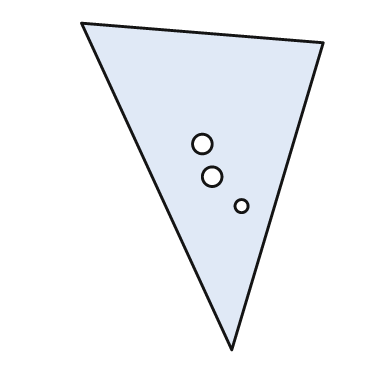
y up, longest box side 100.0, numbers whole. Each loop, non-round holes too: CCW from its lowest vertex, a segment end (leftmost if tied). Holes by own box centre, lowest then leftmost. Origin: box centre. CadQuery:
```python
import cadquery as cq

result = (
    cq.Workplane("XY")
    .moveTo(9.0, -50.0)
    .lineTo(37.0, 44.0)
    .lineTo(-37.0, 50.0)
    .close()
    .moveTo(12.0, -6.0)
    .circle(2.0)
    .moveTo(3.0, 3.0)
    .circle(3.0)
    .moveTo(0.0, 13.0)
    .circle(3.0)
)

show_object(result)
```